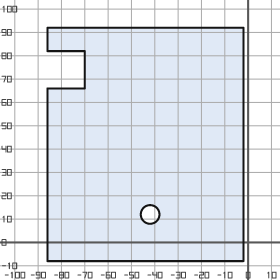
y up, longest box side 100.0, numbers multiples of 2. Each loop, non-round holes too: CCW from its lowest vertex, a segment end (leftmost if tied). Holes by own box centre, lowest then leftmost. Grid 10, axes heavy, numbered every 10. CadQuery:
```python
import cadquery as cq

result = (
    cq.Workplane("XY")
    .moveTo(-86.0, -8.0)
    .lineTo(-2.0, -8.0)
    .lineTo(-2.0, 92.0)
    .lineTo(-86.0, 92.0)
    .lineTo(-86.0, 82.0)
    .lineTo(-70.0, 82.0)
    .lineTo(-70.0, 66.0)
    .lineTo(-86.0, 66.0)
    .close()
    .moveTo(-42.0, 12.0)
    .circle(4.0)
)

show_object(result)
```